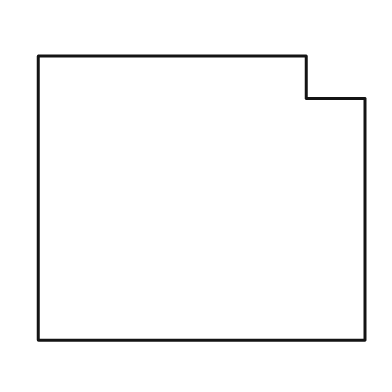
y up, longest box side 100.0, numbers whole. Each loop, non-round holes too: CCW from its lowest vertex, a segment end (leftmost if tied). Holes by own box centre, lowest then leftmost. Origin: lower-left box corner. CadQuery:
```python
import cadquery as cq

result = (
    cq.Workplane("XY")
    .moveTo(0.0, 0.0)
    .lineTo(100.0, 0.0)
    .lineTo(100.0, 74.0)
    .lineTo(82.0, 74.0)
    .lineTo(82.0, 87.0)
    .lineTo(0.0, 87.0)
    .close()
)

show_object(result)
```